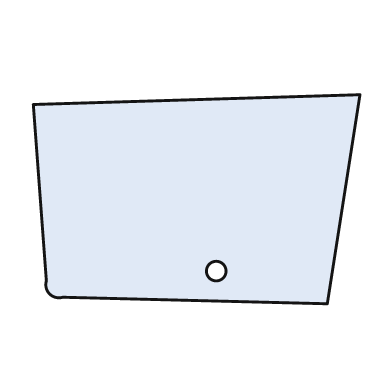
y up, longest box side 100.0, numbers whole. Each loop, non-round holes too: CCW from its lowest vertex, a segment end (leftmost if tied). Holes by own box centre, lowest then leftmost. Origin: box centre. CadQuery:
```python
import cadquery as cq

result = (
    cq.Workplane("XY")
    .moveTo(40.0, -32.0)
    .lineTo(50.0, 32.0)
    .lineTo(-50.0, 29.0)
    .lineTo(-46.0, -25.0)
    .threePointArc((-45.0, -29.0), (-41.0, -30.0))
    .close()
    .moveTo(6.0, -22.0)
    .circle(3.0)
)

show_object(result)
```